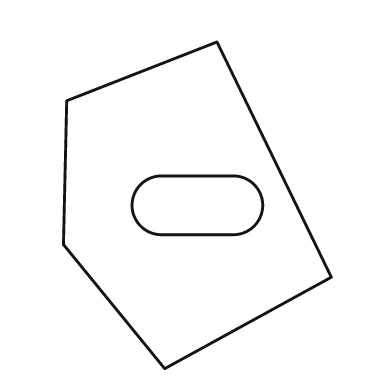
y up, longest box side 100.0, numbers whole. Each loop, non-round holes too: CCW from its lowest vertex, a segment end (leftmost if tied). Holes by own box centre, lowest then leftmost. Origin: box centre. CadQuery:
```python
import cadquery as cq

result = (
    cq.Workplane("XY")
    .moveTo(-10.0, -50.0)
    .lineTo(41.0, -22.0)
    .lineTo(6.0, 50.0)
    .lineTo(-40.0, 32.0)
    .lineTo(-41.0, -12.0)
    .close()
    .moveTo(-11.0, -9.0)
    .lineTo(11.0, -9.0)
    .threePointArc((20.0, 0.0), (11.0, 9.0))
    .lineTo(-11.0, 9.0)
    .threePointArc((-20.0, 0.0), (-11.0, -9.0))
    .close()
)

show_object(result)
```